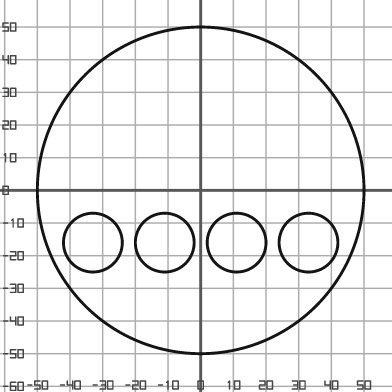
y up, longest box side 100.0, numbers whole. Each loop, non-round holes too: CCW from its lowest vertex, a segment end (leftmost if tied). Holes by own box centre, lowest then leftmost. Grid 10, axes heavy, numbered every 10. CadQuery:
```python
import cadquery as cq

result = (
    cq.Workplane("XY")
    .moveTo(0.0, 0.0)
    .circle(50.0)
    .moveTo(-33.0, -16.0)
    .circle(9.0)
    .moveTo(-11.0, -16.0)
    .circle(9.0)
    .moveTo(11.0, -16.0)
    .circle(9.0)
    .moveTo(33.0, -16.0)
    .circle(9.0)
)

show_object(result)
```